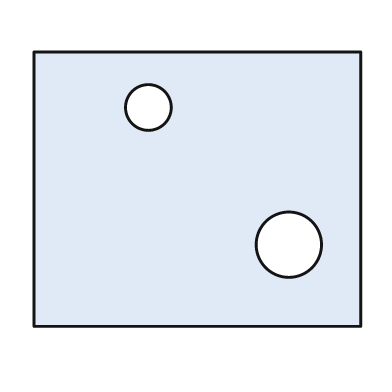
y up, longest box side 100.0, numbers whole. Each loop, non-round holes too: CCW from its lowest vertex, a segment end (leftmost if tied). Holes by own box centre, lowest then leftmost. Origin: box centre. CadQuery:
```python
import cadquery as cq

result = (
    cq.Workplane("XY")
    .moveTo(-50.0, -42.0)
    .lineTo(50.0, -42.0)
    .lineTo(50.0, 42.0)
    .lineTo(-50.0, 42.0)
    .close()
    .moveTo(28.0, -17.0)
    .circle(10.0)
    .moveTo(-15.0, 25.0)
    .circle(7.0)
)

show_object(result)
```